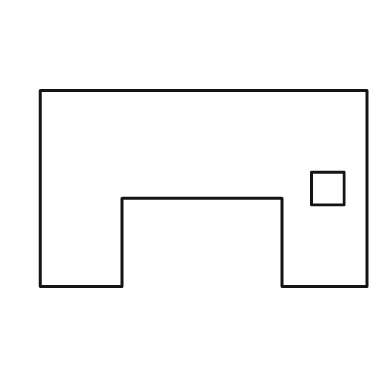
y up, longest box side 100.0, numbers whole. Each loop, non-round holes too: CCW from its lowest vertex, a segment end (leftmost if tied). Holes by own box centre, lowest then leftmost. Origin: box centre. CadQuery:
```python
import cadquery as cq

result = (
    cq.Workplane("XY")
    .moveTo(-50.0, -30.0)
    .lineTo(-25.0, -30.0)
    .lineTo(-25.0, -3.0)
    .lineTo(24.0, -3.0)
    .lineTo(24.0, -30.0)
    .lineTo(50.0, -30.0)
    .lineTo(50.0, 30.0)
    .lineTo(-50.0, 30.0)
    .close()
    .moveTo(33.0, -5.0)
    .lineTo(43.0, -5.0)
    .lineTo(43.0, 5.0)
    .lineTo(33.0, 5.0)
    .close()
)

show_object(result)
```